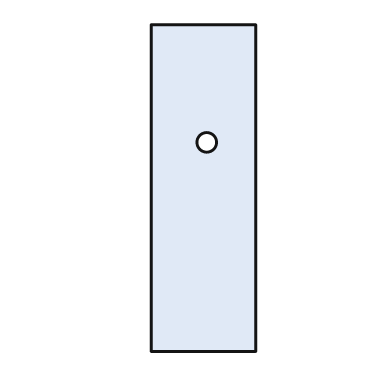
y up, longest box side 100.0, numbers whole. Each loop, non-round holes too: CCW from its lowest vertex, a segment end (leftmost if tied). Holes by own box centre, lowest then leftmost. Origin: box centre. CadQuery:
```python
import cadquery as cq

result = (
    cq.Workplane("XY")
    .moveTo(-16.0, -50.0)
    .lineTo(16.0, -50.0)
    .lineTo(16.0, 50.0)
    .lineTo(-16.0, 50.0)
    .close()
    .moveTo(1.0, 14.0)
    .circle(3.0)
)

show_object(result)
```